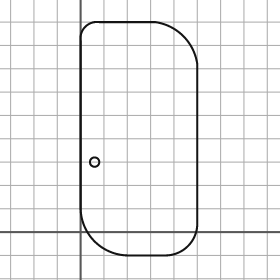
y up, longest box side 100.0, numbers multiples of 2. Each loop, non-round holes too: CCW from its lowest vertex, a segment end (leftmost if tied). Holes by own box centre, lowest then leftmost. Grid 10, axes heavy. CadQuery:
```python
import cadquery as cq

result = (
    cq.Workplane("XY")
    .moveTo(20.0, -10.0)
    .lineTo(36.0, -10.0)
    .threePointArc((46.0, -6.0), (50.0, 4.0))
    .lineTo(50.0, 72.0)
    .threePointArc((44.0, 84.0), (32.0, 90.0))
    .lineTo(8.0, 90.0)
    .threePointArc((2.0, 88.0), (0.0, 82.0))
    .lineTo(0.0, 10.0)
    .threePointArc((6.0, -4.0), (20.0, -10.0))
    .close()
    .moveTo(6.0, 30.0)
    .circle(2.0)
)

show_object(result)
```